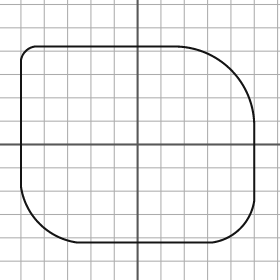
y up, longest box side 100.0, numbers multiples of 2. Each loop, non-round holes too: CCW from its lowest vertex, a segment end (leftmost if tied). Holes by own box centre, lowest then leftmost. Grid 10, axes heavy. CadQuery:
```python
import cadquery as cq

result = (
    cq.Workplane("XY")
    .moveTo(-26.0, -42.0)
    .lineTo(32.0, -42.0)
    .threePointArc((44.0, -36.0), (50.0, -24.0))
    .lineTo(50.0, 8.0)
    .threePointArc((40.0, 32.0), (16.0, 42.0))
    .lineTo(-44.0, 42.0)
    .threePointArc((-48.0, 40.0), (-50.0, 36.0))
    .lineTo(-50.0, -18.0)
    .threePointArc((-42.0, -34.0), (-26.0, -42.0))
    .close()
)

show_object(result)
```